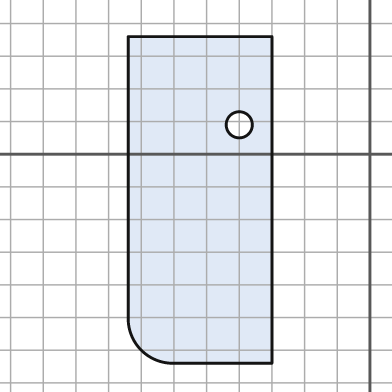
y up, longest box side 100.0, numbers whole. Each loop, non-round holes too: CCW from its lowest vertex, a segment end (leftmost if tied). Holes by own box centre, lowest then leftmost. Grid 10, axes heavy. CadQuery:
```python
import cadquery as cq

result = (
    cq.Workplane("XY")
    .moveTo(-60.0, -64.0)
    .lineTo(-30.0, -64.0)
    .lineTo(-30.0, 36.0)
    .lineTo(-74.0, 36.0)
    .lineTo(-74.0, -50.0)
    .threePointArc((-70.0, -60.0), (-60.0, -64.0))
    .close()
    .moveTo(-40.0, 9.0)
    .circle(4.0)
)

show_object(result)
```